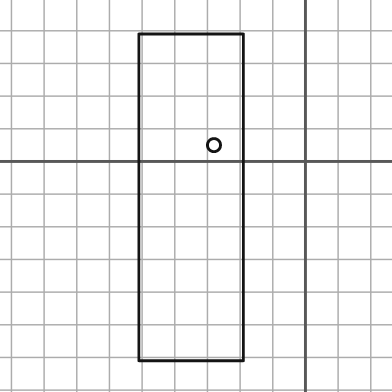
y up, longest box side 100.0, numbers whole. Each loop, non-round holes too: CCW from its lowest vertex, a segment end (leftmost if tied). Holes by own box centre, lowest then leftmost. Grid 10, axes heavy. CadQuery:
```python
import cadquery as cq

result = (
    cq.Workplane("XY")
    .moveTo(-51.0, -61.0)
    .lineTo(-19.0, -61.0)
    .lineTo(-19.0, 39.0)
    .lineTo(-51.0, 39.0)
    .close()
    .moveTo(-28.0, 5.0)
    .circle(2.0)
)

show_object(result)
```